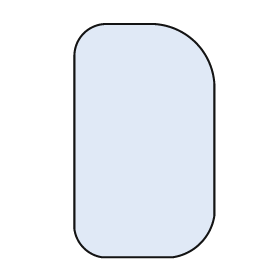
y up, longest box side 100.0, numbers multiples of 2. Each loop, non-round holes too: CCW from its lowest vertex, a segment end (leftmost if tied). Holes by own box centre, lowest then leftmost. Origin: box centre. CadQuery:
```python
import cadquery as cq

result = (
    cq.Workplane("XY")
    .moveTo(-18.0, -50.0)
    .lineTo(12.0, -50.0)
    .threePointArc((24.0, -44.0), (30.0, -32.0))
    .lineTo(30.0, 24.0)
    .threePointArc((22.0, 42.0), (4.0, 50.0))
    .lineTo(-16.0, 50.0)
    .threePointArc((-26.0, 46.0), (-30.0, 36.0))
    .lineTo(-30.0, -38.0)
    .threePointArc((-26.0, -46.0), (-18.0, -50.0))
    .close()
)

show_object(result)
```